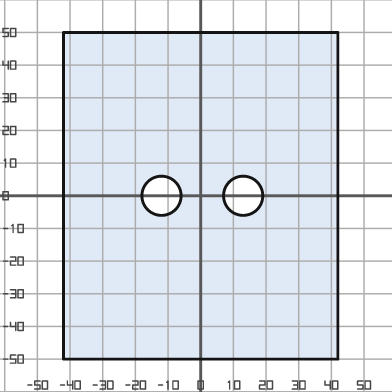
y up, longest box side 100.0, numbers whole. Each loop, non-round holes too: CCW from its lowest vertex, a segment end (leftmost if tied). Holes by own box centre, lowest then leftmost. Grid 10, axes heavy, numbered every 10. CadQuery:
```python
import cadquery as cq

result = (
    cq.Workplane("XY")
    .moveTo(-42.0, -50.0)
    .lineTo(42.0, -50.0)
    .lineTo(42.0, 50.0)
    .lineTo(-42.0, 50.0)
    .close()
    .moveTo(-12.0, 0.0)
    .circle(6.0)
    .moveTo(13.0, 0.0)
    .circle(6.0)
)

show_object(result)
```